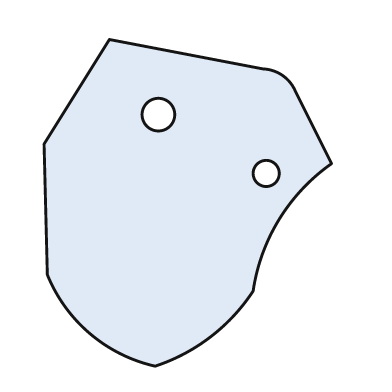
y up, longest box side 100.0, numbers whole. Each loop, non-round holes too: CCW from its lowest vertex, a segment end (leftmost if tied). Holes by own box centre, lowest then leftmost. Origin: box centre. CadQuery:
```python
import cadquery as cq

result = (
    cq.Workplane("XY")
    .moveTo(-10.0, -50.0)
    .threePointArc((7.0, -41.0), (20.0, -27.0))
    .threePointArc((28.0, -5.0), (44.0, 12.0))
    .lineTo(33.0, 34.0)
    .threePointArc((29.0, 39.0), (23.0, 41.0))
    .lineTo(-24.0, 50.0)
    .lineTo(-44.0, 18.0)
    .lineTo(-43.0, -22.0)
    .threePointArc((-30.0, -40.0), (-10.0, -50.0))
    .close()
    .moveTo(24.0, 9.0)
    .circle(4.0)
    .moveTo(-9.0, 27.0)
    .circle(5.0)
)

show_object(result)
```